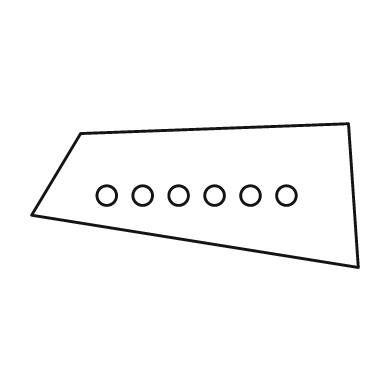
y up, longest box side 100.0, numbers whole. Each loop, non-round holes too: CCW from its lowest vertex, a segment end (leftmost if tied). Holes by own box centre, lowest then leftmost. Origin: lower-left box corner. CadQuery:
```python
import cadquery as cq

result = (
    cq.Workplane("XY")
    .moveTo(100.0, 0.0)
    .lineTo(97.0, 44.0)
    .lineTo(15.0, 41.0)
    .lineTo(0.0, 16.0)
    .close()
    .moveTo(23.0, 22.0)
    .circle(3.0)
    .moveTo(34.0, 22.0)
    .circle(3.0)
    .moveTo(45.0, 22.0)
    .circle(3.0)
    .moveTo(56.0, 22.0)
    .circle(3.0)
    .moveTo(67.0, 22.0)
    .circle(3.0)
    .moveTo(78.0, 22.0)
    .circle(3.0)
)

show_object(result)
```